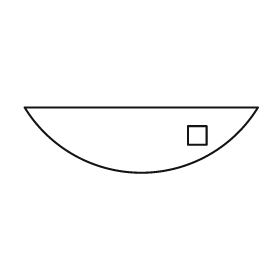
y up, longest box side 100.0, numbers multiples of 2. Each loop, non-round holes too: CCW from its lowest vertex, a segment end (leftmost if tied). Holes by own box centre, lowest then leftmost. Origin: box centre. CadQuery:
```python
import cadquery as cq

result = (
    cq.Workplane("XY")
    .moveTo(-50.0, 14.0)
    .threePointArc((0.0, -14.0), (50.0, 14.0))
    .close()
    .moveTo(20.0, -2.0)
    .lineTo(28.0, -2.0)
    .lineTo(28.0, 6.0)
    .lineTo(20.0, 6.0)
    .close()
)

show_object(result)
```